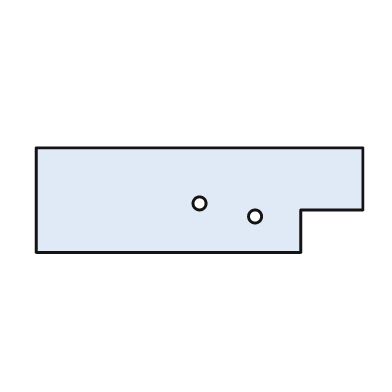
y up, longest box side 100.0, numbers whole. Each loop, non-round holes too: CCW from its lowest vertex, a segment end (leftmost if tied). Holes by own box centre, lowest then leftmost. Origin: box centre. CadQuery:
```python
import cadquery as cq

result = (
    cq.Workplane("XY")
    .moveTo(-50.0, -16.0)
    .lineTo(31.0, -16.0)
    .lineTo(31.0, -3.0)
    .lineTo(50.0, -3.0)
    .lineTo(50.0, 16.0)
    .lineTo(-50.0, 16.0)
    .close()
    .moveTo(17.0, -5.0)
    .circle(2.0)
    .moveTo(0.0, -1.0)
    .circle(2.0)
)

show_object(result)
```